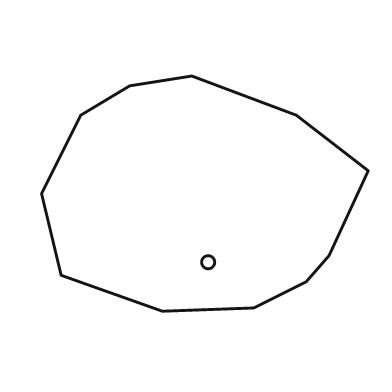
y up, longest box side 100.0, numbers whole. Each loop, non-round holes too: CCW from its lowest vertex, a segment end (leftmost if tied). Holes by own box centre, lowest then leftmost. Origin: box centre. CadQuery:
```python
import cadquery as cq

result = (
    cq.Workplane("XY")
    .moveTo(-13.0, -36.0)
    .lineTo(15.0, -35.0)
    .lineTo(31.0, -27.0)
    .lineTo(38.0, -19.0)
    .lineTo(50.0, 7.0)
    .lineTo(28.0, 24.0)
    .lineTo(-4.0, 36.0)
    .lineTo(-23.0, 33.0)
    .lineTo(-38.0, 24.0)
    .lineTo(-50.0, 0.0)
    .lineTo(-44.0, -25.0)
    .close()
    .moveTo(1.0, -21.0)
    .circle(2.0)
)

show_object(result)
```